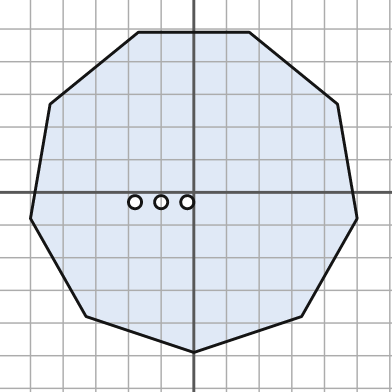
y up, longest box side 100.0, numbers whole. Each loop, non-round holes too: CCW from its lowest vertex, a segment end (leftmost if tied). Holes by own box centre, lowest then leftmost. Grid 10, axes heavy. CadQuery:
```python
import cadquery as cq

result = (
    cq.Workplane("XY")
    .moveTo(0.0, -49.0)
    .lineTo(33.0, -38.0)
    .lineTo(50.0, -8.0)
    .lineTo(44.0, 27.0)
    .lineTo(17.0, 49.0)
    .lineTo(-17.0, 49.0)
    .lineTo(-44.0, 27.0)
    .lineTo(-50.0, -8.0)
    .lineTo(-33.0, -38.0)
    .close()
    .moveTo(-18.0, -3.0)
    .circle(2.0)
    .moveTo(-10.0, -3.0)
    .circle(2.0)
    .moveTo(-2.0, -3.0)
    .circle(2.0)
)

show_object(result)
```